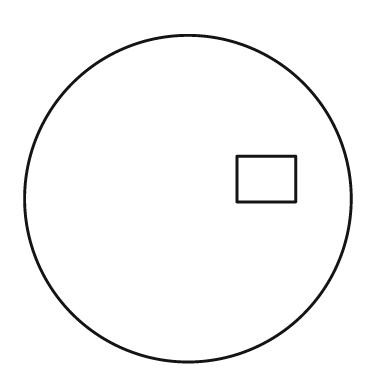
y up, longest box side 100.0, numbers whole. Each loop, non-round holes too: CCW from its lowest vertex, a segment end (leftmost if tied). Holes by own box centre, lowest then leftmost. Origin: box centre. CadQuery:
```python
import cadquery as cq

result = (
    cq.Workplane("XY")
    .moveTo(0.0, 0.0)
    .circle(50.0)
    .moveTo(15.0, -1.0)
    .lineTo(33.0, -1.0)
    .lineTo(33.0, 13.0)
    .lineTo(15.0, 13.0)
    .close()
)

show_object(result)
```